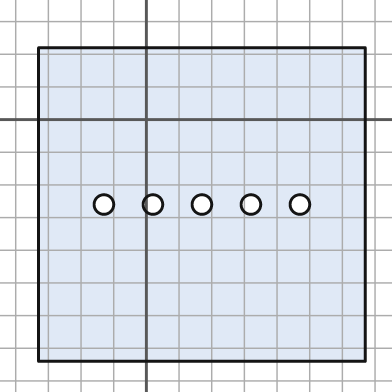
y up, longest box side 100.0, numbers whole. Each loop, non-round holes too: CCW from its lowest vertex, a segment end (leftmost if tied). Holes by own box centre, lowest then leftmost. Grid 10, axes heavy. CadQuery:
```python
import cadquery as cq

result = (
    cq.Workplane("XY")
    .moveTo(-33.0, -74.0)
    .lineTo(67.0, -74.0)
    .lineTo(67.0, 22.0)
    .lineTo(-33.0, 22.0)
    .close()
    .moveTo(-13.0, -26.0)
    .circle(3.0)
    .moveTo(2.0, -26.0)
    .circle(3.0)
    .moveTo(17.0, -26.0)
    .circle(3.0)
    .moveTo(32.0, -26.0)
    .circle(3.0)
    .moveTo(47.0, -26.0)
    .circle(3.0)
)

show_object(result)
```